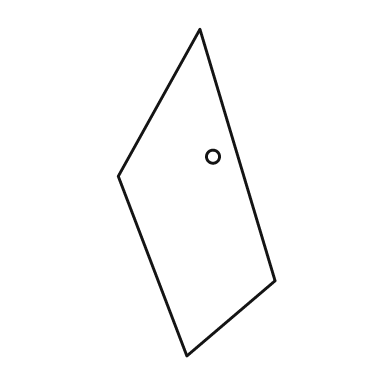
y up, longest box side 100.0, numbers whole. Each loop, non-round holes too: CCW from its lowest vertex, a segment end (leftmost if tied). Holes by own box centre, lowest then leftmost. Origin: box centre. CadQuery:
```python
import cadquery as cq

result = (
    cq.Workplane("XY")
    .moveTo(-3.0, -50.0)
    .lineTo(24.0, -27.0)
    .lineTo(1.0, 50.0)
    .lineTo(-24.0, 5.0)
    .close()
    .moveTo(5.0, 11.0)
    .circle(2.0)
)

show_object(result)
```